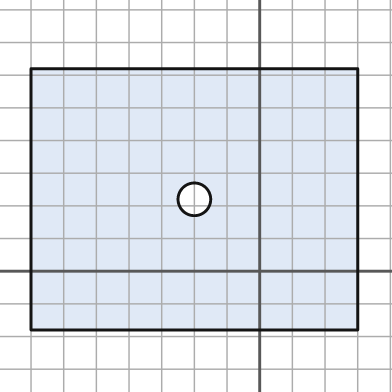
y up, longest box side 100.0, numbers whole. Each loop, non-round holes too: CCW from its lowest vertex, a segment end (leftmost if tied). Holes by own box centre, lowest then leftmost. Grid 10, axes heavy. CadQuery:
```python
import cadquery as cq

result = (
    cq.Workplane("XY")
    .moveTo(-70.0, -18.0)
    .lineTo(30.0, -18.0)
    .lineTo(30.0, 62.0)
    .lineTo(-70.0, 62.0)
    .close()
    .moveTo(-20.0, 22.0)
    .circle(5.0)
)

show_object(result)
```